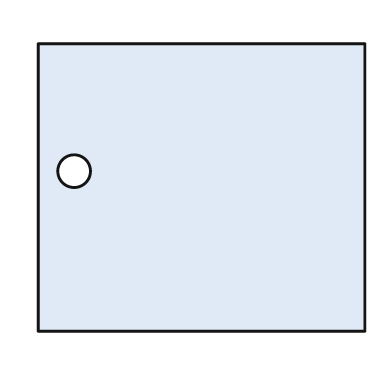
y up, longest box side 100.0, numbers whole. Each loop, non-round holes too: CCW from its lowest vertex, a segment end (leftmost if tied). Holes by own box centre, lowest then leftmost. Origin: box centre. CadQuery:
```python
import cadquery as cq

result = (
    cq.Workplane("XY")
    .moveTo(-50.0, -44.0)
    .lineTo(50.0, -44.0)
    .lineTo(50.0, 44.0)
    .lineTo(-50.0, 44.0)
    .close()
    .moveTo(-39.0, 5.0)
    .circle(5.0)
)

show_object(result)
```